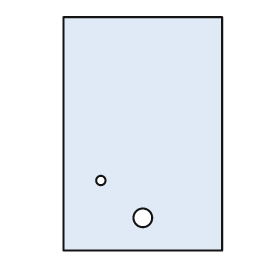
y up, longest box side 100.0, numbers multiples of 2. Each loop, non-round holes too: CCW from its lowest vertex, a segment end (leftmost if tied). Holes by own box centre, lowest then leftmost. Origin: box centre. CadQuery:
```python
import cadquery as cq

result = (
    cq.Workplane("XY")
    .moveTo(-34.0, -50.0)
    .lineTo(34.0, -50.0)
    .lineTo(34.0, 50.0)
    .lineTo(-34.0, 50.0)
    .close()
    .moveTo(0.0, -36.0)
    .circle(4.0)
    .moveTo(-18.0, -20.0)
    .circle(2.0)
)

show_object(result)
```